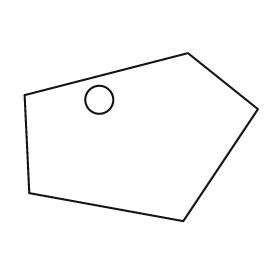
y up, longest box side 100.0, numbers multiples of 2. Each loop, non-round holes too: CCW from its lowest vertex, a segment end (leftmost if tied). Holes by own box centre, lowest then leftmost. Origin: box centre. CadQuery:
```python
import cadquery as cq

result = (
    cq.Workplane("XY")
    .moveTo(18.0, -36.0)
    .lineTo(50.0, 12.0)
    .lineTo(20.0, 36.0)
    .lineTo(-50.0, 18.0)
    .lineTo(-48.0, -24.0)
    .close()
    .moveTo(-18.0, 16.0)
    .circle(6.0)
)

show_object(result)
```